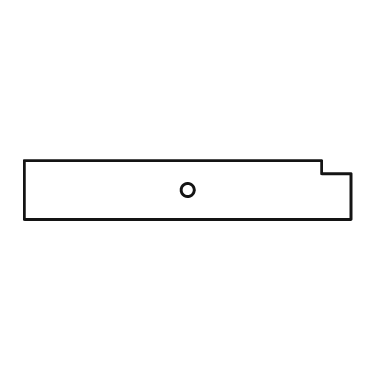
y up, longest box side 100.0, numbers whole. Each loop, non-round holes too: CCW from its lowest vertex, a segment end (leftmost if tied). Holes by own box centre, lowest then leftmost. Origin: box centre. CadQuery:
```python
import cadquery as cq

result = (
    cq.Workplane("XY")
    .moveTo(-50.0, -9.0)
    .lineTo(50.0, -9.0)
    .lineTo(50.0, 5.0)
    .lineTo(41.0, 5.0)
    .lineTo(41.0, 9.0)
    .lineTo(-50.0, 9.0)
    .close()
    .moveTo(0.0, 0.0)
    .circle(2.0)
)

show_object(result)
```